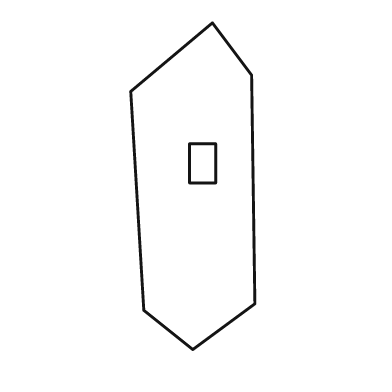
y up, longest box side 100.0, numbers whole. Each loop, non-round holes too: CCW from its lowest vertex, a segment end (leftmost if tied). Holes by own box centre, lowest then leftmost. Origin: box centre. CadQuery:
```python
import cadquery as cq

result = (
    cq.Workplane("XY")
    .moveTo(0.0, -50.0)
    .lineTo(19.0, -36.0)
    .lineTo(18.0, 34.0)
    .lineTo(6.0, 50.0)
    .lineTo(-19.0, 29.0)
    .lineTo(-15.0, -38.0)
    .close()
    .moveTo(-1.0, 1.0)
    .lineTo(7.0, 1.0)
    .lineTo(7.0, 13.0)
    .lineTo(-1.0, 13.0)
    .close()
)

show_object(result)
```